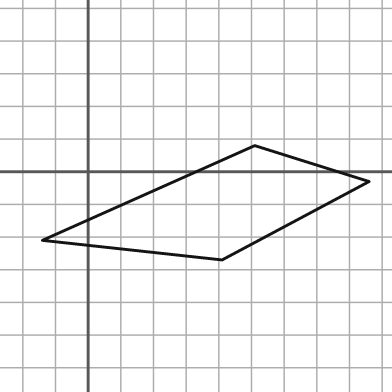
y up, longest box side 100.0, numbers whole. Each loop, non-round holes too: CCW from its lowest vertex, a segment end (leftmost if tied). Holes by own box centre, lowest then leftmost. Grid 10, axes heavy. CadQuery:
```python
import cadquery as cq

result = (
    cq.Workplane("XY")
    .moveTo(41.0, -27.0)
    .lineTo(86.0, -3.0)
    .lineTo(51.0, 8.0)
    .lineTo(-14.0, -21.0)
    .close()
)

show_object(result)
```